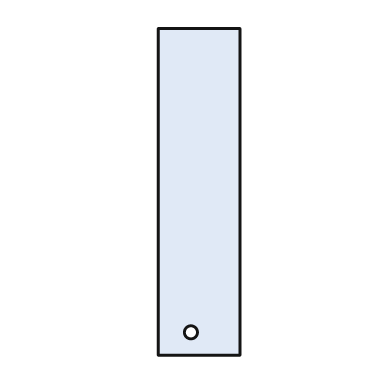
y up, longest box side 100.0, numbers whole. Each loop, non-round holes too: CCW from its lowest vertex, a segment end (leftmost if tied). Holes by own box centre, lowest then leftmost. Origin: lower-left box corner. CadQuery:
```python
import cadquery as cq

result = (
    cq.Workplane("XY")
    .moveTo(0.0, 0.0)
    .lineTo(25.0, 0.0)
    .lineTo(25.0, 100.0)
    .lineTo(0.0, 100.0)
    .close()
    .moveTo(10.0, 7.0)
    .circle(2.0)
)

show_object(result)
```